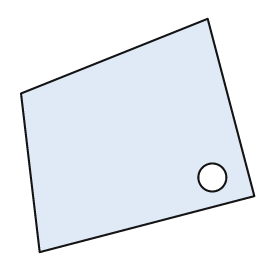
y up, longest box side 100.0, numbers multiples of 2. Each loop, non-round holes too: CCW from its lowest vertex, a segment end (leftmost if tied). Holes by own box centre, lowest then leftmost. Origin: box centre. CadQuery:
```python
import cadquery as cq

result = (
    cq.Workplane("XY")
    .moveTo(-42.0, -50.0)
    .lineTo(50.0, -26.0)
    .lineTo(30.0, 50.0)
    .lineTo(-50.0, 18.0)
    .close()
    .moveTo(32.0, -18.0)
    .circle(6.0)
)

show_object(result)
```